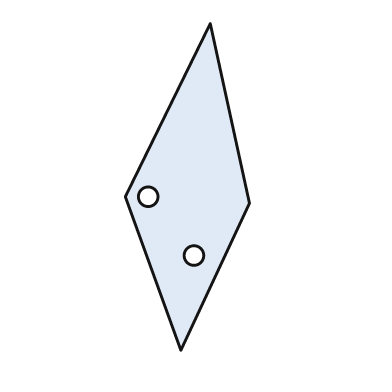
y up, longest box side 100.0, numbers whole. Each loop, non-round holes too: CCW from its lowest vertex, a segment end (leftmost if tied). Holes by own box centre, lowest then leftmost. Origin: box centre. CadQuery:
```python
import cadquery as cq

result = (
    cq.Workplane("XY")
    .moveTo(-2.0, -50.0)
    .lineTo(19.0, -5.0)
    .lineTo(7.0, 50.0)
    .lineTo(-19.0, -3.0)
    .close()
    .moveTo(2.0, -21.0)
    .circle(3.0)
    .moveTo(-12.0, -3.0)
    .circle(3.0)
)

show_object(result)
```